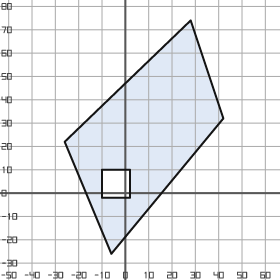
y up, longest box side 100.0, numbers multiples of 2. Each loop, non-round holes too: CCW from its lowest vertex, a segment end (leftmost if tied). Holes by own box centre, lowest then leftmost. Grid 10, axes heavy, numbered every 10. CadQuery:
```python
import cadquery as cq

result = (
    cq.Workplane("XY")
    .moveTo(-6.0, -26.0)
    .lineTo(42.0, 32.0)
    .lineTo(28.0, 74.0)
    .lineTo(-26.0, 22.0)
    .close()
    .moveTo(-10.0, -2.0)
    .lineTo(2.0, -2.0)
    .lineTo(2.0, 10.0)
    .lineTo(-10.0, 10.0)
    .close()
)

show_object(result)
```